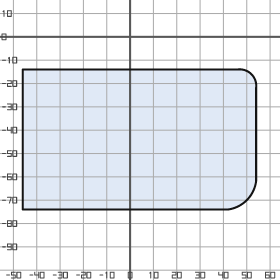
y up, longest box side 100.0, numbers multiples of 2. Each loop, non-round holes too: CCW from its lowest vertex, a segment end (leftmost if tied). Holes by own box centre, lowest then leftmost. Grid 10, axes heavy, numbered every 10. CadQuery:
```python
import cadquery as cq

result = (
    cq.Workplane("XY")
    .moveTo(-46.0, -74.0)
    .lineTo(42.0, -74.0)
    .threePointArc((50.0, -70.0), (54.0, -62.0))
    .lineTo(54.0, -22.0)
    .threePointArc((52.0, -16.0), (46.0, -14.0))
    .lineTo(-46.0, -14.0)
    .close()
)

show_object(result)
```